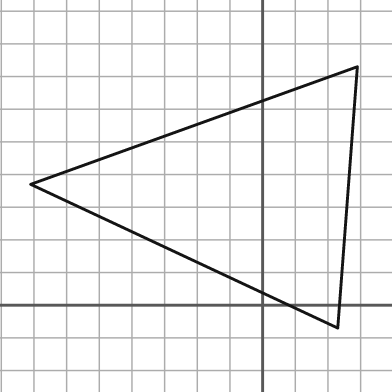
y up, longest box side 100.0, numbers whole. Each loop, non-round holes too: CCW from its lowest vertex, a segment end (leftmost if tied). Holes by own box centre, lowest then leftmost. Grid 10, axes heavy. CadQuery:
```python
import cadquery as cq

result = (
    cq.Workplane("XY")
    .moveTo(23.0, -7.0)
    .lineTo(29.0, 73.0)
    .lineTo(-71.0, 37.0)
    .close()
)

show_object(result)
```